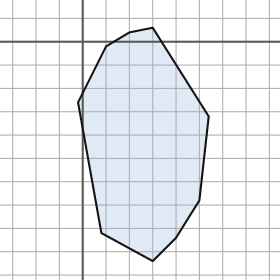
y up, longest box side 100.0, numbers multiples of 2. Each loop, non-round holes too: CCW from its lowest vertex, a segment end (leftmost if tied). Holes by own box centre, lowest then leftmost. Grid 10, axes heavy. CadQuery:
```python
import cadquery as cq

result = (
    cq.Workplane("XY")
    .moveTo(30.0, -94.0)
    .lineTo(40.0, -84.0)
    .lineTo(50.0, -68.0)
    .lineTo(54.0, -32.0)
    .lineTo(30.0, 6.0)
    .lineTo(20.0, 4.0)
    .lineTo(10.0, -2.0)
    .lineTo(-2.0, -26.0)
    .lineTo(8.0, -82.0)
    .close()
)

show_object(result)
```